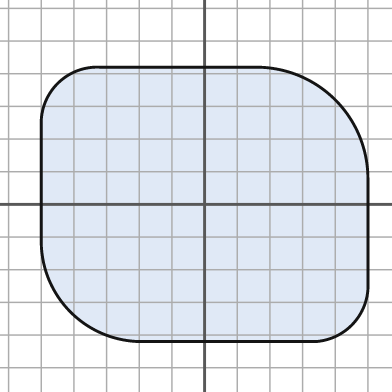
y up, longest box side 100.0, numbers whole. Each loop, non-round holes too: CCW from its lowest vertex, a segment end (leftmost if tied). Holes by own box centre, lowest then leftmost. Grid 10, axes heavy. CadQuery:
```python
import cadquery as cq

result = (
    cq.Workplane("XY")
    .moveTo(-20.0, -42.0)
    .lineTo(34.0, -42.0)
    .threePointArc((45.0, -37.0), (50.0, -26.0))
    .lineTo(50.0, 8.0)
    .threePointArc((40.0, 32.0), (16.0, 42.0))
    .lineTo(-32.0, 42.0)
    .threePointArc((-45.0, 37.0), (-50.0, 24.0))
    .lineTo(-50.0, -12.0)
    .threePointArc((-41.0, -33.0), (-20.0, -42.0))
    .close()
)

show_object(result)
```